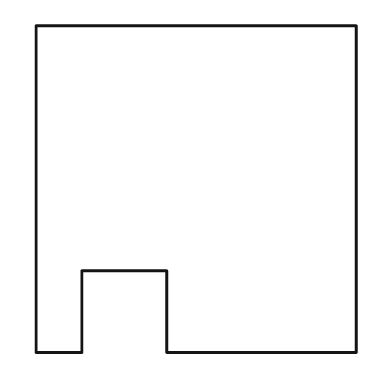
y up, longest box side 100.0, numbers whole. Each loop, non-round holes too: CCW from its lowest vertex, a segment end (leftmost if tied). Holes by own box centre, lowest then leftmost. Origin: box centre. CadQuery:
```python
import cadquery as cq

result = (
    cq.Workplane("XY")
    .moveTo(-49.0, -50.0)
    .lineTo(-35.0, -50.0)
    .lineTo(-35.0, -25.0)
    .lineTo(-9.0, -25.0)
    .lineTo(-9.0, -50.0)
    .lineTo(49.0, -50.0)
    .lineTo(49.0, 50.0)
    .lineTo(-49.0, 50.0)
    .close()
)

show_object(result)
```